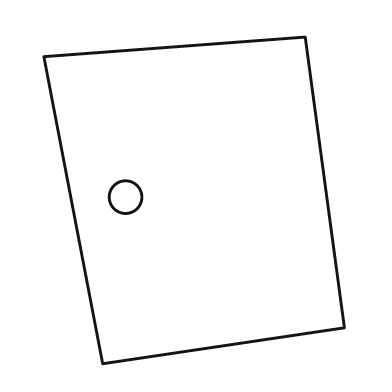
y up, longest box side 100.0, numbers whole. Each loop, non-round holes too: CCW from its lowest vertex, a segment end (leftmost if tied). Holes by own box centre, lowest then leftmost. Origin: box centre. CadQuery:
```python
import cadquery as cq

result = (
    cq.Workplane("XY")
    .moveTo(-28.0, -50.0)
    .lineTo(46.0, -39.0)
    .lineTo(34.0, 50.0)
    .lineTo(-46.0, 44.0)
    .close()
    .moveTo(-21.0, 1.0)
    .circle(5.0)
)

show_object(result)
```